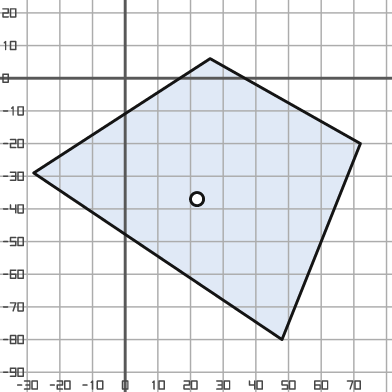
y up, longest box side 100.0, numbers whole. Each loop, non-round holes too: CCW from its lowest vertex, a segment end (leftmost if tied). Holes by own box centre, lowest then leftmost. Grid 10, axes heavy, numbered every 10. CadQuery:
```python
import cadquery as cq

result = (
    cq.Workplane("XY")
    .moveTo(48.0, -80.0)
    .lineTo(72.0, -20.0)
    .lineTo(26.0, 6.0)
    .lineTo(-28.0, -29.0)
    .close()
    .moveTo(22.0, -37.0)
    .circle(2.0)
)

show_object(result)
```